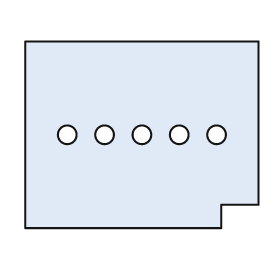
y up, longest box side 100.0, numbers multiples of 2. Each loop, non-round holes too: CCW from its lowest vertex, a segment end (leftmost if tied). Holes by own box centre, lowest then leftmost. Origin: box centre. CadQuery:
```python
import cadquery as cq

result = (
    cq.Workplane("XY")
    .moveTo(-50.0, -40.0)
    .lineTo(34.0, -40.0)
    .lineTo(34.0, -30.0)
    .lineTo(50.0, -30.0)
    .lineTo(50.0, 40.0)
    .lineTo(-50.0, 40.0)
    .close()
    .moveTo(-32.0, 0.0)
    .circle(4.0)
    .moveTo(-16.0, 0.0)
    .circle(4.0)
    .moveTo(0.0, 0.0)
    .circle(4.0)
    .moveTo(16.0, 0.0)
    .circle(4.0)
    .moveTo(32.0, 0.0)
    .circle(4.0)
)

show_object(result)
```